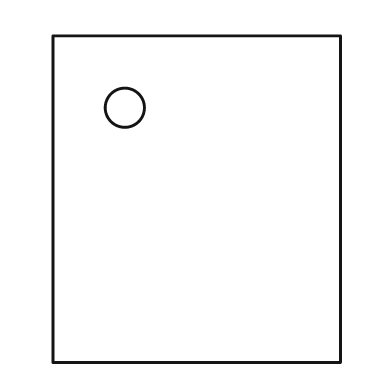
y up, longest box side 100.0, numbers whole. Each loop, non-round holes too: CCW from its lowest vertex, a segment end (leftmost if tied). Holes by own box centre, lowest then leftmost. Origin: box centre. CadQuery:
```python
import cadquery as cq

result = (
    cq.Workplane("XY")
    .moveTo(-44.0, -50.0)
    .lineTo(44.0, -50.0)
    .lineTo(44.0, 50.0)
    .lineTo(-44.0, 50.0)
    .close()
    .moveTo(-22.0, 28.0)
    .circle(6.0)
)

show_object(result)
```